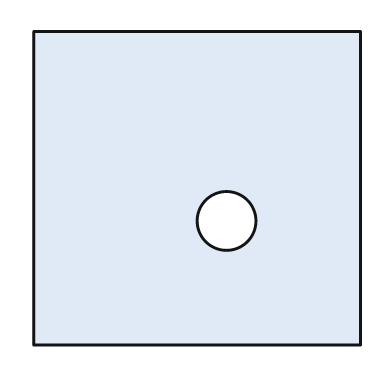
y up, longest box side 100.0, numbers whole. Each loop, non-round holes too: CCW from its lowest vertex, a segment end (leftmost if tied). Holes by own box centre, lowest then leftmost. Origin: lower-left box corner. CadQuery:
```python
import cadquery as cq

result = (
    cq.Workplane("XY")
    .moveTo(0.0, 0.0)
    .lineTo(100.0, 0.0)
    .lineTo(100.0, 96.0)
    .lineTo(0.0, 96.0)
    .close()
    .moveTo(59.0, 38.0)
    .circle(9.0)
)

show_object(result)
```